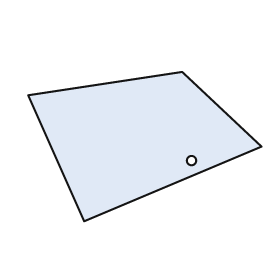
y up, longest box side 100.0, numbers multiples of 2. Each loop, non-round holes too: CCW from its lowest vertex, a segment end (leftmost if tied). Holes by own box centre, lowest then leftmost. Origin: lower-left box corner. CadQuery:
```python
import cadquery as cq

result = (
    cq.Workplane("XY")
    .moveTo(24.0, 0.0)
    .lineTo(100.0, 32.0)
    .lineTo(66.0, 64.0)
    .lineTo(0.0, 54.0)
    .close()
    .moveTo(70.0, 26.0)
    .circle(2.0)
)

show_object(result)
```